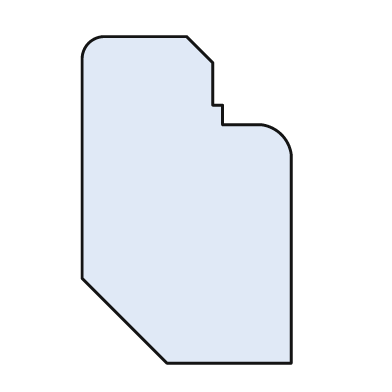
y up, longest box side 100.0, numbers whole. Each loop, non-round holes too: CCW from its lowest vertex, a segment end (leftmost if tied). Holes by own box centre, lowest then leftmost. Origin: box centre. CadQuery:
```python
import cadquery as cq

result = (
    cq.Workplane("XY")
    .moveTo(-6.0, -50.0)
    .lineTo(32.0, -50.0)
    .lineTo(32.0, 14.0)
    .threePointArc((29.0, 20.0), (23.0, 23.0))
    .lineTo(11.0, 23.0)
    .lineTo(11.0, 29.0)
    .lineTo(8.0, 29.0)
    .lineTo(8.0, 42.0)
    .lineTo(0.0, 50.0)
    .lineTo(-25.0, 50.0)
    .threePointArc((-30.0, 48.0), (-32.0, 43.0))
    .lineTo(-32.0, -24.0)
    .close()
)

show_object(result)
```